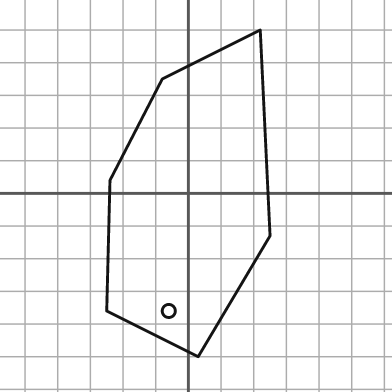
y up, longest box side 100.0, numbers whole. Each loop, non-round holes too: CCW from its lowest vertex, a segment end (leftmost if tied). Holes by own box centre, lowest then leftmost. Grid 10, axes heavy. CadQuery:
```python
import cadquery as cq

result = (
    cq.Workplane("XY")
    .moveTo(3.0, -50.0)
    .lineTo(25.0, -13.0)
    .lineTo(22.0, 50.0)
    .lineTo(-8.0, 35.0)
    .lineTo(-24.0, 4.0)
    .lineTo(-25.0, -36.0)
    .close()
    .moveTo(-6.0, -36.0)
    .circle(2.0)
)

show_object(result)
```